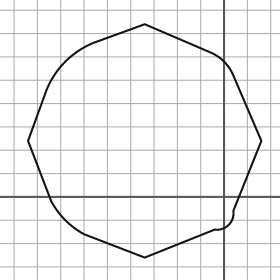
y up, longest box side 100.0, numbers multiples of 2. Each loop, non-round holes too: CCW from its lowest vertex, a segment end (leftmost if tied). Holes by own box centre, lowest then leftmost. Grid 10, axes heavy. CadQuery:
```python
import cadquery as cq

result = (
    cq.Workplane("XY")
    .moveTo(-34.0, -26.0)
    .lineTo(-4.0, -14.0)
    .threePointArc((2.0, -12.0), (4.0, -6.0))
    .lineTo(16.0, 24.0)
    .lineTo(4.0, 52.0)
    .threePointArc((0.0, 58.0), (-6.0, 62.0))
    .lineTo(-34.0, 74.0)
    .lineTo(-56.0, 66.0)
    .threePointArc((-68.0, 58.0), (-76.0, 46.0))
    .lineTo(-84.0, 24.0)
    .lineTo(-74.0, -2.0)
    .threePointArc((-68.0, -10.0), (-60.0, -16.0))
    .close()
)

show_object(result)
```